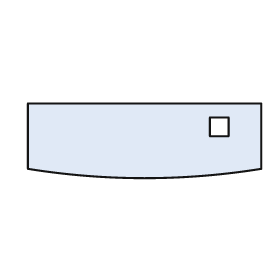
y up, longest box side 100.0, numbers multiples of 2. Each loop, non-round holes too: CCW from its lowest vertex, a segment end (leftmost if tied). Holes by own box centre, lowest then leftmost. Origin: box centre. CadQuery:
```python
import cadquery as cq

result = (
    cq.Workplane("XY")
    .moveTo(-50.0, -12.0)
    .threePointArc((0.0, -16.0), (50.0, -12.0))
    .lineTo(50.0, 16.0)
    .lineTo(-50.0, 16.0)
    .close()
    .moveTo(28.0, 2.0)
    .lineTo(36.0, 2.0)
    .lineTo(36.0, 10.0)
    .lineTo(28.0, 10.0)
    .close()
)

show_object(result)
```